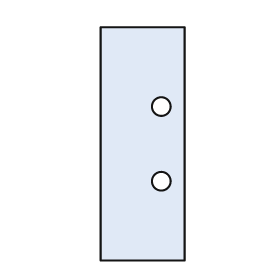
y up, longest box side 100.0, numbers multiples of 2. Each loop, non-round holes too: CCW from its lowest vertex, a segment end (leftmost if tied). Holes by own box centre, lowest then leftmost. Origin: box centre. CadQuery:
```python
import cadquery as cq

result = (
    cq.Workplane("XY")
    .moveTo(-18.0, -50.0)
    .lineTo(18.0, -50.0)
    .lineTo(18.0, 50.0)
    .lineTo(-18.0, 50.0)
    .close()
    .moveTo(8.0, -16.0)
    .circle(4.0)
    .moveTo(8.0, 16.0)
    .circle(4.0)
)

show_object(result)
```